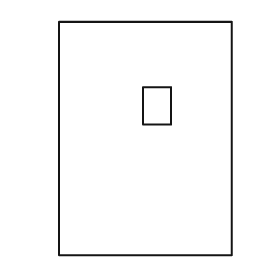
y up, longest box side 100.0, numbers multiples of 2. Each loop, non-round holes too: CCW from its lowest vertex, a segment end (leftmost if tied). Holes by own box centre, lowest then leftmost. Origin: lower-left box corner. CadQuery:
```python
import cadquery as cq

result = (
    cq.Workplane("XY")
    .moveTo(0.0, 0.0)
    .lineTo(74.0, 0.0)
    .lineTo(74.0, 100.0)
    .lineTo(0.0, 100.0)
    .close()
    .moveTo(36.0, 56.0)
    .lineTo(48.0, 56.0)
    .lineTo(48.0, 72.0)
    .lineTo(36.0, 72.0)
    .close()
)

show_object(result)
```